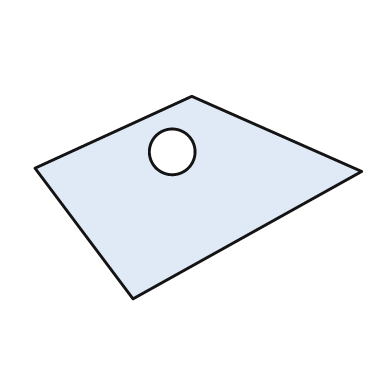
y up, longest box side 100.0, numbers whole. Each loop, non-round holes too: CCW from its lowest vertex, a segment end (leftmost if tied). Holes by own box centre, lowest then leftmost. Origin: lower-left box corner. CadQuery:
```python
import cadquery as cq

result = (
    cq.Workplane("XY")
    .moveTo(30.0, 0.0)
    .lineTo(100.0, 39.0)
    .lineTo(48.0, 62.0)
    .lineTo(0.0, 40.0)
    .close()
    .moveTo(42.0, 45.0)
    .circle(7.0)
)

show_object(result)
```